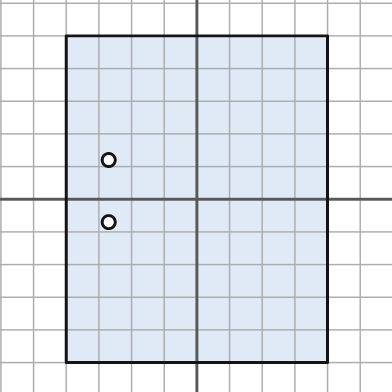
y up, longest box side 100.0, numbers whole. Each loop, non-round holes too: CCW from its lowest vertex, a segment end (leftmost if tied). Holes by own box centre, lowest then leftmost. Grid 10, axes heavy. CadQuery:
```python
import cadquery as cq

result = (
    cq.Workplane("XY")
    .moveTo(-40.0, -50.0)
    .lineTo(40.0, -50.0)
    .lineTo(40.0, 50.0)
    .lineTo(-40.0, 50.0)
    .close()
    .moveTo(-27.0, -7.0)
    .circle(2.0)
    .moveTo(-27.0, 12.0)
    .circle(2.0)
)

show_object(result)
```